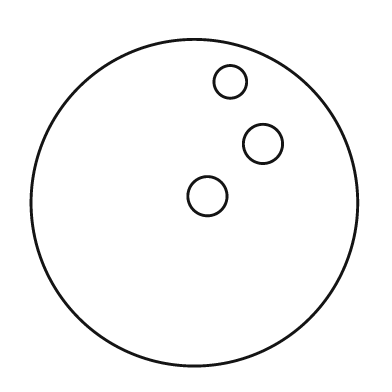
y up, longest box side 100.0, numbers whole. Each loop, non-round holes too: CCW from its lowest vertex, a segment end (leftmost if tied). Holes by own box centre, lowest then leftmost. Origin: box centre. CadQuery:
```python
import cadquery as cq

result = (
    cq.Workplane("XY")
    .moveTo(0.0, 0.0)
    .circle(50.0)
    .moveTo(4.0, 2.0)
    .circle(6.0)
    .moveTo(21.0, 18.0)
    .circle(6.0)
    .moveTo(11.0, 37.0)
    .circle(5.0)
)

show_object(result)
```